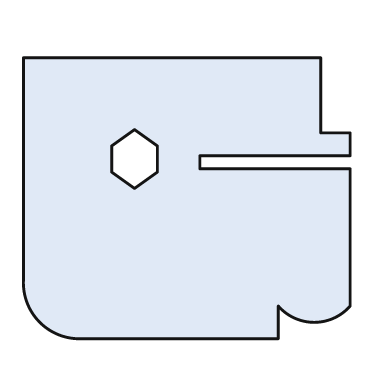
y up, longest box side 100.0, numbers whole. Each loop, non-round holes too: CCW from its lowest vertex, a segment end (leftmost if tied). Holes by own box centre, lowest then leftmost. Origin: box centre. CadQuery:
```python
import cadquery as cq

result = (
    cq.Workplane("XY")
    .moveTo(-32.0, -43.0)
    .lineTo(28.0, -43.0)
    .lineTo(28.0, -33.0)
    .threePointArc((39.0, -38.0), (50.0, -33.0))
    .lineTo(50.0, 9.0)
    .lineTo(4.0, 9.0)
    .lineTo(4.0, 13.0)
    .lineTo(50.0, 13.0)
    .lineTo(50.0, 20.0)
    .lineTo(41.0, 20.0)
    .lineTo(41.0, 43.0)
    .lineTo(-50.0, 43.0)
    .lineTo(-50.0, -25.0)
    .threePointArc((-45.0, -38.0), (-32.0, -43.0))
    .close()
    .moveTo(-16.0, 3.0)
    .lineTo(-9.0, 8.0)
    .lineTo(-9.0, 16.0)
    .lineTo(-16.0, 21.0)
    .lineTo(-23.0, 16.0)
    .lineTo(-23.0, 8.0)
    .close()
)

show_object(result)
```